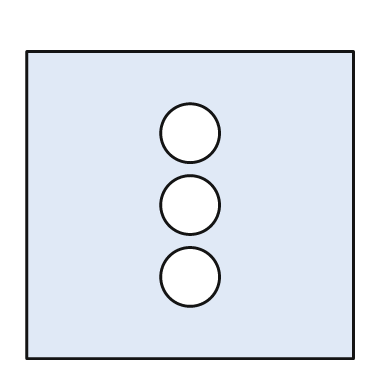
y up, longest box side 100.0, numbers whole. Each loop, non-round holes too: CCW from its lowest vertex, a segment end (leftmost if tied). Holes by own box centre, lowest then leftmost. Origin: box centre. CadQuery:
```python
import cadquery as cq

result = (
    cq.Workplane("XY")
    .moveTo(-50.0, -47.0)
    .lineTo(50.0, -47.0)
    .lineTo(50.0, 47.0)
    .lineTo(-50.0, 47.0)
    .close()
    .moveTo(0.0, -22.0)
    .circle(9.0)
    .moveTo(0.0, 0.0)
    .circle(9.0)
    .moveTo(0.0, 22.0)
    .circle(9.0)
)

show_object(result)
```